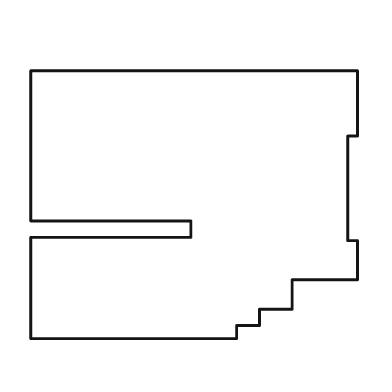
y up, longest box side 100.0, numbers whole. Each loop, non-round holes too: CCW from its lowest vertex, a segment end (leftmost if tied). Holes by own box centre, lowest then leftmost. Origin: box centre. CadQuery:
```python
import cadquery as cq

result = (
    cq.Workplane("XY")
    .moveTo(-50.0, -41.0)
    .lineTo(13.0, -41.0)
    .lineTo(13.0, -37.0)
    .lineTo(20.0, -37.0)
    .lineTo(20.0, -32.0)
    .lineTo(30.0, -32.0)
    .lineTo(30.0, -23.0)
    .lineTo(50.0, -23.0)
    .lineTo(50.0, -11.0)
    .lineTo(47.0, -11.0)
    .lineTo(47.0, 21.0)
    .lineTo(50.0, 21.0)
    .lineTo(50.0, 41.0)
    .lineTo(-50.0, 41.0)
    .lineTo(-50.0, -5.0)
    .lineTo(-1.0, -5.0)
    .lineTo(-1.0, -10.0)
    .lineTo(-50.0, -10.0)
    .close()
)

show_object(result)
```